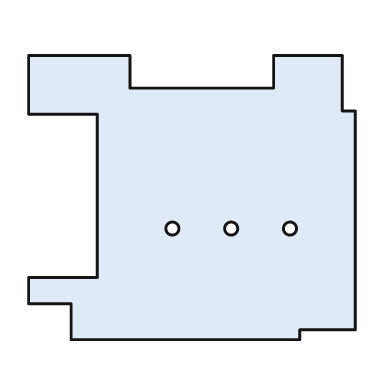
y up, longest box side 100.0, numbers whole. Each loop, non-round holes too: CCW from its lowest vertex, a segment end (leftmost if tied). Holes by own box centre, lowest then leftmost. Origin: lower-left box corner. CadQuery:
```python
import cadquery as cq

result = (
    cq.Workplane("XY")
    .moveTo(13.0, 0.0)
    .lineTo(83.0, 0.0)
    .lineTo(83.0, 3.0)
    .lineTo(100.0, 3.0)
    .lineTo(100.0, 70.0)
    .lineTo(96.0, 70.0)
    .lineTo(96.0, 87.0)
    .lineTo(75.0, 87.0)
    .lineTo(75.0, 77.0)
    .lineTo(31.0, 77.0)
    .lineTo(31.0, 87.0)
    .lineTo(0.0, 87.0)
    .lineTo(0.0, 69.0)
    .lineTo(21.0, 69.0)
    .lineTo(21.0, 19.0)
    .lineTo(0.0, 19.0)
    .lineTo(0.0, 11.0)
    .lineTo(13.0, 11.0)
    .close()
    .moveTo(44.0, 34.0)
    .circle(2.0)
    .moveTo(62.0, 34.0)
    .circle(2.0)
    .moveTo(80.0, 34.0)
    .circle(2.0)
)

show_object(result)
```